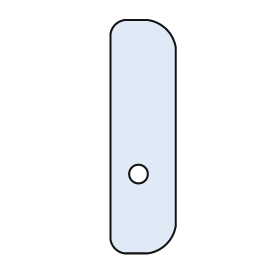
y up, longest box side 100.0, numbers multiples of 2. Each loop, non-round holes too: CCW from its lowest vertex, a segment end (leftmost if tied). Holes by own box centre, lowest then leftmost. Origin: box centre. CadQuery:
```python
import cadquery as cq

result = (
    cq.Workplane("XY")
    .moveTo(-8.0, -50.0)
    .lineTo(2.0, -50.0)
    .threePointArc((10.0, -46.0), (14.0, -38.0))
    .lineTo(14.0, 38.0)
    .threePointArc((10.0, 46.0), (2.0, 50.0))
    .lineTo(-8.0, 50.0)
    .threePointArc((-12.0, 48.0), (-14.0, 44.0))
    .lineTo(-14.0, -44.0)
    .threePointArc((-12.0, -48.0), (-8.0, -50.0))
    .close()
    .moveTo(-2.0, -16.0)
    .circle(4.0)
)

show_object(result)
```